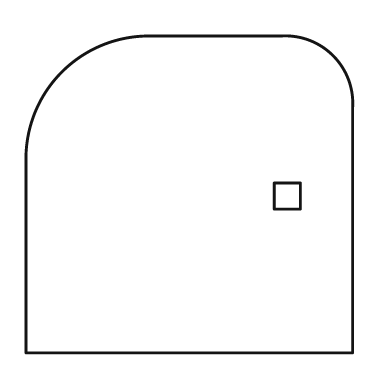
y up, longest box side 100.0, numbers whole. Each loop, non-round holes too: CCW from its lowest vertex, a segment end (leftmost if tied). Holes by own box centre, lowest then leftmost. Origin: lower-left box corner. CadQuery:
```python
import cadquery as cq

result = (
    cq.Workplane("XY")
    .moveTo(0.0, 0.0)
    .lineTo(100.0, 0.0)
    .lineTo(100.0, 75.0)
    .threePointArc((94.0, 91.0), (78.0, 97.0))
    .lineTo(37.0, 97.0)
    .threePointArc((11.0, 86.0), (0.0, 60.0))
    .close()
    .moveTo(76.0, 44.0)
    .lineTo(84.0, 44.0)
    .lineTo(84.0, 52.0)
    .lineTo(76.0, 52.0)
    .close()
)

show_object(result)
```